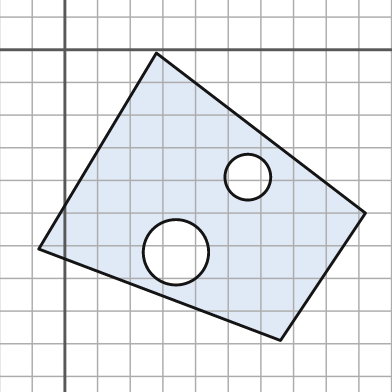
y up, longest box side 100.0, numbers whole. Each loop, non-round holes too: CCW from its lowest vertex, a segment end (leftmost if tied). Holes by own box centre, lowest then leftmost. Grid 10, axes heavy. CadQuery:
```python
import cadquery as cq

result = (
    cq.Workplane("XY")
    .moveTo(66.0, -89.0)
    .lineTo(92.0, -50.0)
    .lineTo(28.0, -1.0)
    .lineTo(-8.0, -61.0)
    .close()
    .moveTo(34.0, -62.0)
    .circle(10.0)
    .moveTo(56.0, -39.0)
    .circle(7.0)
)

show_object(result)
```